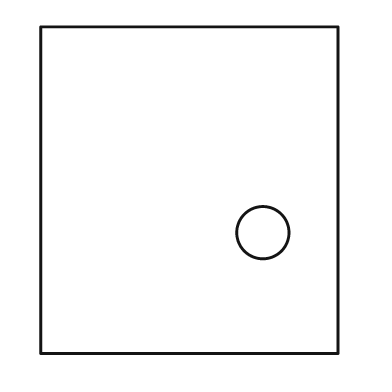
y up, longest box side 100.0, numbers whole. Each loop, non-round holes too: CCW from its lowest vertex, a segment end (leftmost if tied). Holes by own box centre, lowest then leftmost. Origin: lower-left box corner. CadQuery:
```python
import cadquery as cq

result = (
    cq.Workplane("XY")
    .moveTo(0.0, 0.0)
    .lineTo(91.0, 0.0)
    .lineTo(91.0, 100.0)
    .lineTo(0.0, 100.0)
    .close()
    .moveTo(68.0, 37.0)
    .circle(8.0)
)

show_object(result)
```